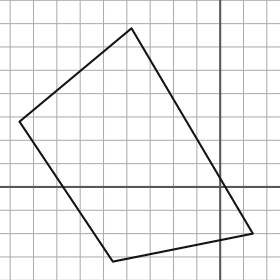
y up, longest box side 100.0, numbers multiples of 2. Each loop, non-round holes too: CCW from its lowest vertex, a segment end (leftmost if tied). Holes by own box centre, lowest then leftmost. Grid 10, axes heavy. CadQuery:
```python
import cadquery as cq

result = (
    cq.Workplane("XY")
    .moveTo(-46.0, -32.0)
    .lineTo(14.0, -20.0)
    .lineTo(-38.0, 68.0)
    .lineTo(-86.0, 28.0)
    .close()
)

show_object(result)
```